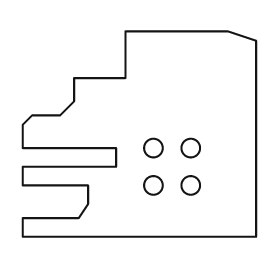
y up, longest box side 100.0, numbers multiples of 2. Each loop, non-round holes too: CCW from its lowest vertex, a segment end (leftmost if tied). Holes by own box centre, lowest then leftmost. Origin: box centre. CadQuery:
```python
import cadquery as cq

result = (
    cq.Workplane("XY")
    .moveTo(-50.0, -44.0)
    .lineTo(50.0, -44.0)
    .lineTo(50.0, 40.0)
    .lineTo(38.0, 44.0)
    .lineTo(-6.0, 44.0)
    .lineTo(-6.0, 24.0)
    .lineTo(-28.0, 24.0)
    .lineTo(-28.0, 14.0)
    .lineTo(-34.0, 8.0)
    .lineTo(-46.0, 8.0)
    .lineTo(-50.0, 4.0)
    .lineTo(-50.0, -6.0)
    .lineTo(-10.0, -6.0)
    .lineTo(-10.0, -14.0)
    .lineTo(-50.0, -14.0)
    .lineTo(-50.0, -22.0)
    .lineTo(-22.0, -22.0)
    .lineTo(-22.0, -30.0)
    .lineTo(-26.0, -36.0)
    .lineTo(-50.0, -36.0)
    .close()
    .moveTo(6.0, -22.0)
    .circle(4.0)
    .moveTo(22.0, -22.0)
    .circle(4.0)
    .moveTo(6.0, -6.0)
    .circle(4.0)
    .moveTo(22.0, -6.0)
    .circle(4.0)
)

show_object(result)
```